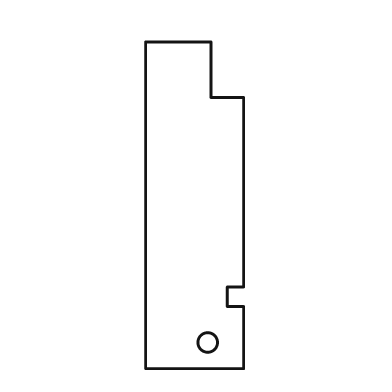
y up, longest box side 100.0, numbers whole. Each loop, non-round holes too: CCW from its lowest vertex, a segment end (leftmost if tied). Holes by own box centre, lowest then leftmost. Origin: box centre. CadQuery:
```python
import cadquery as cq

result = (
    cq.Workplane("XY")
    .moveTo(-15.0, -50.0)
    .lineTo(15.0, -50.0)
    .lineTo(15.0, -31.0)
    .lineTo(10.0, -31.0)
    .lineTo(10.0, -25.0)
    .lineTo(15.0, -25.0)
    .lineTo(15.0, 33.0)
    .lineTo(5.0, 33.0)
    .lineTo(5.0, 50.0)
    .lineTo(-15.0, 50.0)
    .close()
    .moveTo(4.0, -42.0)
    .circle(3.0)
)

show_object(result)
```